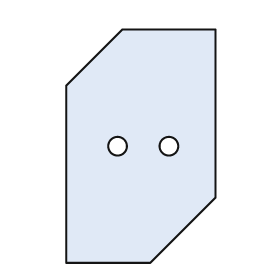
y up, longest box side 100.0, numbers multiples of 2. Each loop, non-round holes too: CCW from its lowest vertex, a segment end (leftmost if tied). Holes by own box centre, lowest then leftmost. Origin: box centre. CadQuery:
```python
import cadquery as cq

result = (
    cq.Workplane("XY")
    .moveTo(-32.0, -50.0)
    .lineTo(4.0, -50.0)
    .lineTo(32.0, -22.0)
    .lineTo(32.0, 50.0)
    .lineTo(-8.0, 50.0)
    .lineTo(-32.0, 26.0)
    .close()
    .moveTo(-10.0, 0.0)
    .circle(4.0)
    .moveTo(12.0, 0.0)
    .circle(4.0)
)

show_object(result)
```